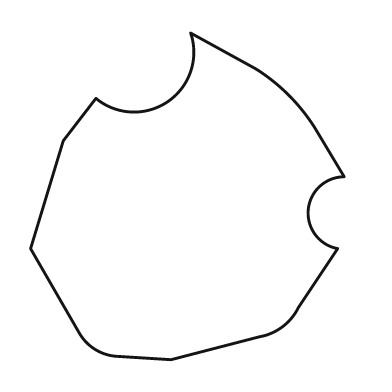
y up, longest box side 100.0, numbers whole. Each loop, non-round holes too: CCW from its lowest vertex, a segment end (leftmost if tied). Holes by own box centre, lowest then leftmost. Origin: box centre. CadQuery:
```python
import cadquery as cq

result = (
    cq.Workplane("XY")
    .moveTo(-5.0, -50.0)
    .lineTo(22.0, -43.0)
    .threePointArc((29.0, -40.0), (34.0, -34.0))
    .lineTo(46.0, -16.0)
    .threePointArc((37.0, -4.0), (48.0, 6.0))
    .lineTo(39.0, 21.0)
    .threePointArc((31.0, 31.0), (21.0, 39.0))
    .lineTo(1.0, 50.0)
    .threePointArc((-6.0, 29.0), (-28.0, 30.0))
    .lineTo(-38.0, 17.0)
    .lineTo(-48.0, -16.0)
    .lineTo(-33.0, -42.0)
    .threePointArc((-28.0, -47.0), (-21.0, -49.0))
    .close()
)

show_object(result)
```